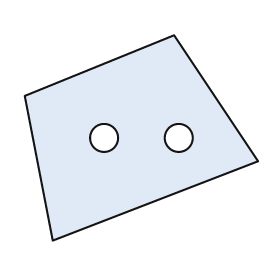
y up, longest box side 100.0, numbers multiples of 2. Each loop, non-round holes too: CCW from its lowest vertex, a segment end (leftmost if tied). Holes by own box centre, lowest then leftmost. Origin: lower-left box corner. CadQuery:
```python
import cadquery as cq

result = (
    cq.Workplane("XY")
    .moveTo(12.0, 0.0)
    .lineTo(100.0, 34.0)
    .lineTo(64.0, 88.0)
    .lineTo(0.0, 62.0)
    .close()
    .moveTo(34.0, 44.0)
    .circle(6.0)
    .moveTo(66.0, 44.0)
    .circle(6.0)
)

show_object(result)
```